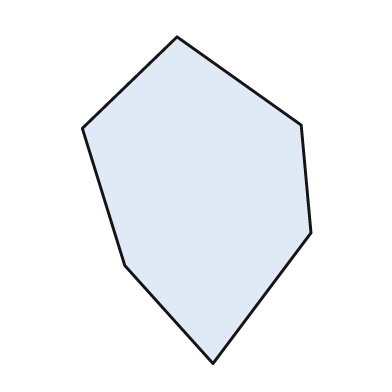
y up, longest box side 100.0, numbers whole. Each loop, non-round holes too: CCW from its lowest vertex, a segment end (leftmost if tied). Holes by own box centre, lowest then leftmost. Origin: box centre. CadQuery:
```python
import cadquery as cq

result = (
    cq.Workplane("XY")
    .moveTo(5.0, -50.0)
    .lineTo(35.0, -10.0)
    .lineTo(32.0, 23.0)
    .lineTo(-6.0, 50.0)
    .lineTo(-35.0, 22.0)
    .lineTo(-22.0, -20.0)
    .close()
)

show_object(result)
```